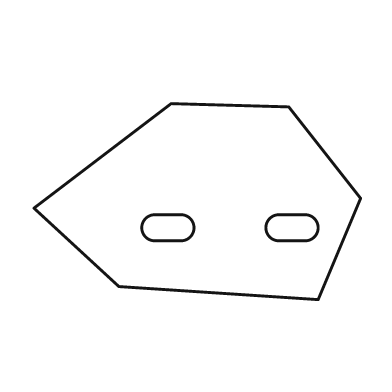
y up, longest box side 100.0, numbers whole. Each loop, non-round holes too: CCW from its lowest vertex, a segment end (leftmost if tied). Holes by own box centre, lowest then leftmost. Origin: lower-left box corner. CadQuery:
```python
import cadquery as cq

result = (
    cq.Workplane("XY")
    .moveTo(87.0, 0.0)
    .lineTo(100.0, 31.0)
    .lineTo(78.0, 59.0)
    .lineTo(42.0, 60.0)
    .lineTo(0.0, 28.0)
    .lineTo(26.0, 4.0)
    .close()
    .moveTo(37.0, 18.0)
    .lineTo(45.0, 18.0)
    .threePointArc((49.0, 22.0), (45.0, 26.0))
    .lineTo(37.0, 26.0)
    .threePointArc((33.0, 22.0), (37.0, 18.0))
    .close()
    .moveTo(75.0, 18.0)
    .lineTo(83.0, 18.0)
    .threePointArc((87.0, 22.0), (83.0, 26.0))
    .lineTo(75.0, 26.0)
    .threePointArc((71.0, 22.0), (75.0, 18.0))
    .close()
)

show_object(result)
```